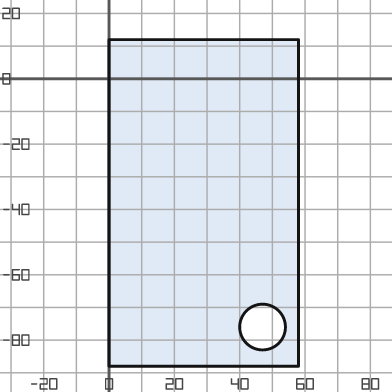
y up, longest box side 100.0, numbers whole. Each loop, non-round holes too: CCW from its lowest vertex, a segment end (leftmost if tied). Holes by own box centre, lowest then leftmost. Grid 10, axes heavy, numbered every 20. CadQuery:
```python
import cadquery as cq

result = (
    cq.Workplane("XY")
    .moveTo(0.0, -88.0)
    .lineTo(58.0, -88.0)
    .lineTo(58.0, 12.0)
    .lineTo(0.0, 12.0)
    .close()
    .moveTo(47.0, -76.0)
    .circle(7.0)
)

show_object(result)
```